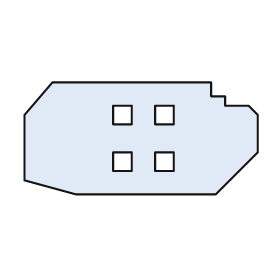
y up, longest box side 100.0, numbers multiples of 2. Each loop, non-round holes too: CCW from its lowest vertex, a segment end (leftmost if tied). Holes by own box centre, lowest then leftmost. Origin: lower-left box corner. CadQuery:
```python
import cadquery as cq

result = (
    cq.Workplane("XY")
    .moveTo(22.0, 0.0)
    .lineTo(82.0, 0.0)
    .lineTo(100.0, 18.0)
    .lineTo(100.0, 34.0)
    .lineTo(96.0, 38.0)
    .lineTo(86.0, 38.0)
    .lineTo(86.0, 42.0)
    .lineTo(80.0, 42.0)
    .lineTo(80.0, 48.0)
    .lineTo(12.0, 48.0)
    .lineTo(0.0, 34.0)
    .lineTo(0.0, 6.0)
    .close()
    .moveTo(38.0, 10.0)
    .lineTo(46.0, 10.0)
    .lineTo(46.0, 18.0)
    .lineTo(38.0, 18.0)
    .close()
    .moveTo(56.0, 10.0)
    .lineTo(64.0, 10.0)
    .lineTo(64.0, 18.0)
    .lineTo(56.0, 18.0)
    .close()
    .moveTo(38.0, 30.0)
    .lineTo(46.0, 30.0)
    .lineTo(46.0, 38.0)
    .lineTo(38.0, 38.0)
    .close()
    .moveTo(56.0, 30.0)
    .lineTo(64.0, 30.0)
    .lineTo(64.0, 38.0)
    .lineTo(56.0, 38.0)
    .close()
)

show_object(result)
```